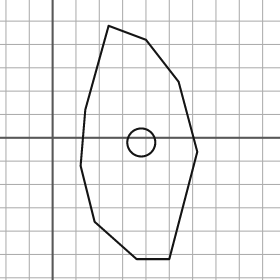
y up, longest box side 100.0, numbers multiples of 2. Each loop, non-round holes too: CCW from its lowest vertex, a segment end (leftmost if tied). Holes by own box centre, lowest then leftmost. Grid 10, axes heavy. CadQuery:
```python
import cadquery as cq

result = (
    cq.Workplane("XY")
    .moveTo(36.0, -52.0)
    .lineTo(50.0, -52.0)
    .lineTo(62.0, -6.0)
    .lineTo(54.0, 24.0)
    .lineTo(40.0, 42.0)
    .lineTo(24.0, 48.0)
    .lineTo(14.0, 12.0)
    .lineTo(12.0, -12.0)
    .lineTo(18.0, -36.0)
    .close()
    .moveTo(38.0, -2.0)
    .circle(6.0)
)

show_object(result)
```